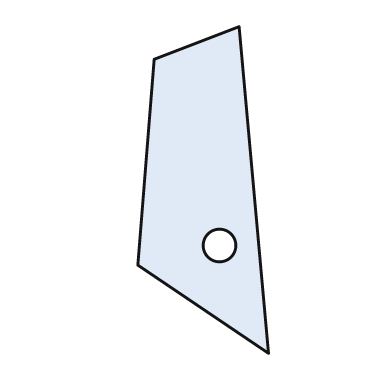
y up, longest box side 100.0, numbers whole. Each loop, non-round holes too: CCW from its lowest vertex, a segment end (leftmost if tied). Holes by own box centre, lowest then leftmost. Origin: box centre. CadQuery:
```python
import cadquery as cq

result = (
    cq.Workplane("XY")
    .moveTo(20.0, -50.0)
    .lineTo(11.0, 50.0)
    .lineTo(-15.0, 40.0)
    .lineTo(-20.0, -23.0)
    .close()
    .moveTo(5.0, -17.0)
    .circle(5.0)
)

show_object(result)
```